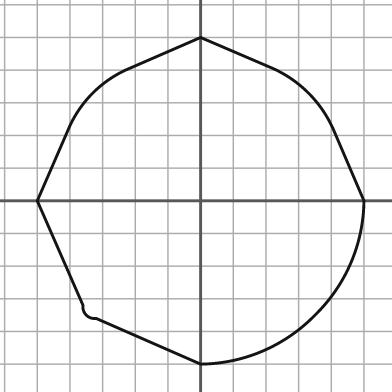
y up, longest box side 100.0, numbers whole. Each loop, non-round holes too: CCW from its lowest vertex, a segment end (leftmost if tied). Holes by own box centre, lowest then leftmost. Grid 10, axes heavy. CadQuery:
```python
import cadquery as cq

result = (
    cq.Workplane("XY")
    .moveTo(0.0, -50.0)
    .threePointArc((19.0, -46.0), (35.0, -35.0))
    .threePointArc((46.0, -19.0), (50.0, 0.0))
    .lineTo(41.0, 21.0)
    .threePointArc((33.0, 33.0), (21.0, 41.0))
    .lineTo(0.0, 50.0)
    .lineTo(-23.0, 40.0)
    .threePointArc((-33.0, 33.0), (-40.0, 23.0))
    .lineTo(-50.0, 0.0)
    .lineTo(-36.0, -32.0)
    .threePointArc((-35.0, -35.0), (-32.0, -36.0))
    .close()
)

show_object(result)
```